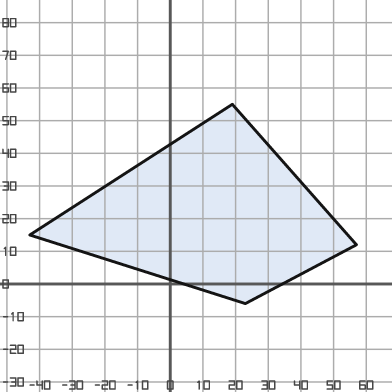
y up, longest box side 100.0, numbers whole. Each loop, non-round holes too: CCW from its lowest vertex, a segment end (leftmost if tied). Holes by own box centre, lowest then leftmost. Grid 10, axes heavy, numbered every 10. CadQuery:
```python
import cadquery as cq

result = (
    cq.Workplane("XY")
    .moveTo(23.0, -6.0)
    .lineTo(57.0, 12.0)
    .lineTo(19.0, 55.0)
    .lineTo(-43.0, 15.0)
    .close()
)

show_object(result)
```